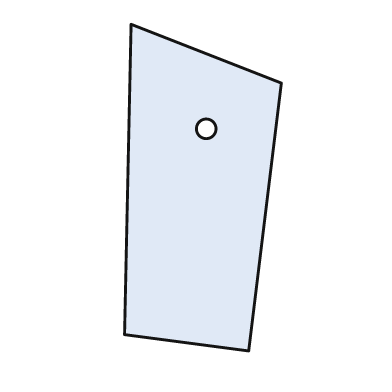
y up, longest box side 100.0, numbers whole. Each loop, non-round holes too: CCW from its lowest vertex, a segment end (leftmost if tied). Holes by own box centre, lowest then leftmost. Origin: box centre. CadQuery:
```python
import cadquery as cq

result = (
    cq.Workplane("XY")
    .moveTo(14.0, -50.0)
    .lineTo(24.0, 32.0)
    .lineTo(-22.0, 50.0)
    .lineTo(-24.0, -45.0)
    .close()
    .moveTo(1.0, 18.0)
    .circle(3.0)
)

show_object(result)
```